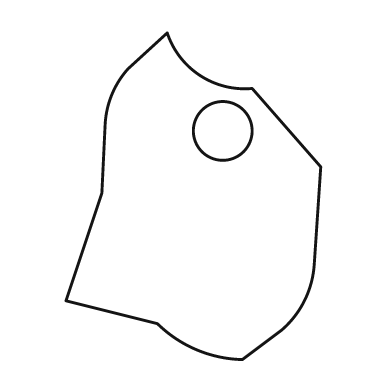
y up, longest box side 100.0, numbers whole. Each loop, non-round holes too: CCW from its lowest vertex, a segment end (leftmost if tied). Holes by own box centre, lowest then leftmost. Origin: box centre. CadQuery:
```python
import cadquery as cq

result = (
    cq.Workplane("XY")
    .moveTo(15.0, -50.0)
    .lineTo(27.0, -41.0)
    .threePointArc((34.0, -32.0), (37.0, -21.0))
    .lineTo(39.0, 9.0)
    .lineTo(18.0, 33.0)
    .threePointArc((2.0, 37.0), (-8.0, 50.0))
    .lineTo(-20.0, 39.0)
    .threePointArc((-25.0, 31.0), (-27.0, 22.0))
    .lineTo(-28.0, 1.0)
    .lineTo(-39.0, -32.0)
    .lineTo(-11.0, -39.0)
    .threePointArc((1.0, -47.0), (15.0, -50.0))
    .close()
    .moveTo(9.0, 20.0)
    .circle(9.0)
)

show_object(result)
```